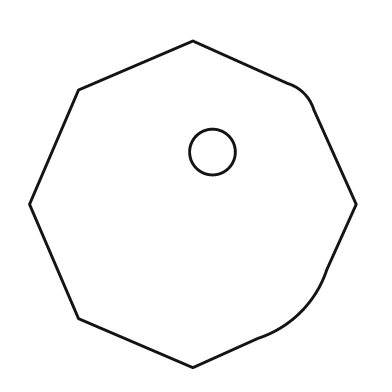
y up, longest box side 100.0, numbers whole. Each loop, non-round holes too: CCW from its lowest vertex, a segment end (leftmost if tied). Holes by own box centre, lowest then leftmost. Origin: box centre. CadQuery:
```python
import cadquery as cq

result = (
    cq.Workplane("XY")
    .moveTo(0.0, -50.0)
    .lineTo(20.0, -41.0)
    .threePointArc((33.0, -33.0), (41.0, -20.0))
    .lineTo(50.0, 0.0)
    .lineTo(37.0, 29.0)
    .threePointArc((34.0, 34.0), (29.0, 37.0))
    .lineTo(0.0, 50.0)
    .lineTo(-35.0, 35.0)
    .lineTo(-50.0, 0.0)
    .lineTo(-35.0, -35.0)
    .close()
    .moveTo(6.0, 16.0)
    .circle(7.0)
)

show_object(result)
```